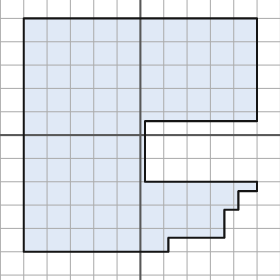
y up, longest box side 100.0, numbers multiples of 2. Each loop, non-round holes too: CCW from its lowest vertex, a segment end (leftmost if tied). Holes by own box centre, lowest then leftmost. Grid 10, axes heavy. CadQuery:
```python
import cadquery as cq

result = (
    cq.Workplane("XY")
    .moveTo(-50.0, -50.0)
    .lineTo(12.0, -50.0)
    .lineTo(12.0, -44.0)
    .lineTo(36.0, -44.0)
    .lineTo(36.0, -32.0)
    .lineTo(42.0, -32.0)
    .lineTo(42.0, -24.0)
    .lineTo(50.0, -24.0)
    .lineTo(50.0, -20.0)
    .lineTo(2.0, -20.0)
    .lineTo(2.0, 6.0)
    .lineTo(50.0, 6.0)
    .lineTo(50.0, 50.0)
    .lineTo(-50.0, 50.0)
    .close()
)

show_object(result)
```